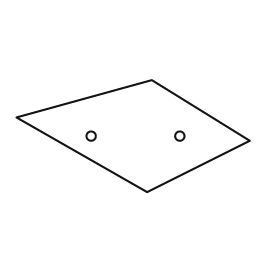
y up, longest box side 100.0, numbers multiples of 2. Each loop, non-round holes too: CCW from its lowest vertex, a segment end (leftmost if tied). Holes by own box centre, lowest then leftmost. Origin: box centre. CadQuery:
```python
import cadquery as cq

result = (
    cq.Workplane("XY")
    .moveTo(6.0, -24.0)
    .lineTo(50.0, -2.0)
    .lineTo(8.0, 24.0)
    .lineTo(-50.0, 8.0)
    .close()
    .moveTo(-18.0, 0.0)
    .circle(2.0)
    .moveTo(20.0, 0.0)
    .circle(2.0)
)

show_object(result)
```